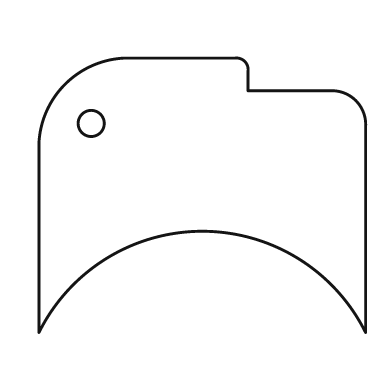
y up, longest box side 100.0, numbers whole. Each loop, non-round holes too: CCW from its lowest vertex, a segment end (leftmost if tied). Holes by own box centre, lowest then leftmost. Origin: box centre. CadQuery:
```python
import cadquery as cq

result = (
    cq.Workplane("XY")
    .moveTo(-50.0, -42.0)
    .threePointArc((0.0, -11.0), (50.0, -42.0))
    .lineTo(50.0, 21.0)
    .threePointArc((47.0, 29.0), (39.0, 32.0))
    .lineTo(14.0, 32.0)
    .lineTo(14.0, 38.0)
    .threePointArc((13.0, 41.0), (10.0, 42.0))
    .lineTo(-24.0, 42.0)
    .threePointArc((-42.0, 34.0), (-50.0, 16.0))
    .close()
    .moveTo(-34.0, 22.0)
    .circle(4.0)
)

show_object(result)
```